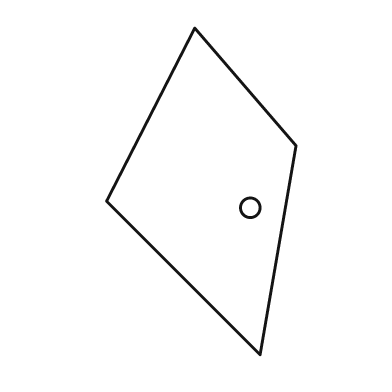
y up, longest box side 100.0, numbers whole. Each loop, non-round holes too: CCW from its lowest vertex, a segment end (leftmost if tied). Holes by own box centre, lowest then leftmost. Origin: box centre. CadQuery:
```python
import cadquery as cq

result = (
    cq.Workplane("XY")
    .moveTo(18.0, -50.0)
    .lineTo(29.0, 14.0)
    .lineTo(-2.0, 50.0)
    .lineTo(-29.0, -3.0)
    .close()
    .moveTo(15.0, -5.0)
    .circle(3.0)
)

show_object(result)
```